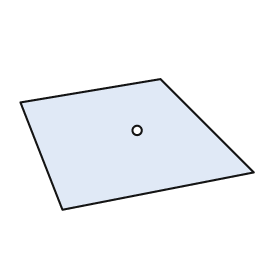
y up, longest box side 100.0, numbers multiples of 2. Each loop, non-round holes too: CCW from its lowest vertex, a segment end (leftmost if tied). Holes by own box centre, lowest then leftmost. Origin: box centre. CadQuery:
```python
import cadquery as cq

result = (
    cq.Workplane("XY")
    .moveTo(-32.0, -28.0)
    .lineTo(50.0, -12.0)
    .lineTo(10.0, 28.0)
    .lineTo(-50.0, 18.0)
    .close()
    .moveTo(0.0, 6.0)
    .circle(2.0)
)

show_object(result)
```